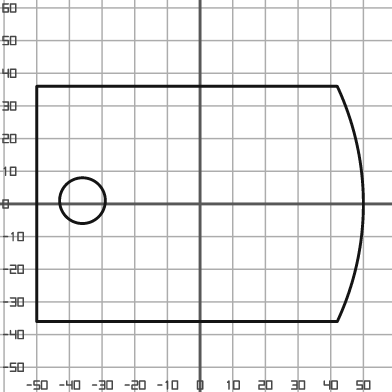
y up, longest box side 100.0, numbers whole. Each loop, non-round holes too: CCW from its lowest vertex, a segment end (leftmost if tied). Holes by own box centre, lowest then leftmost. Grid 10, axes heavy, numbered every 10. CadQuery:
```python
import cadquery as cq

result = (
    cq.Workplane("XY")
    .moveTo(-50.0, -36.0)
    .lineTo(42.0, -36.0)
    .threePointArc((50.0, 0.0), (42.0, 36.0))
    .lineTo(-50.0, 36.0)
    .close()
    .moveTo(-36.0, 1.0)
    .circle(7.0)
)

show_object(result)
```